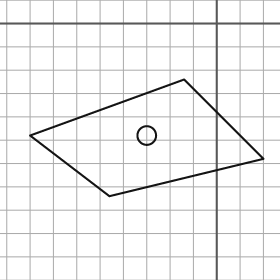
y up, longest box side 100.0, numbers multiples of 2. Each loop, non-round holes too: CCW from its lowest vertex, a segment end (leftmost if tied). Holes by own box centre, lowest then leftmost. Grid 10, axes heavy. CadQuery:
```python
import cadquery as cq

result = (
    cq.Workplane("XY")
    .moveTo(-46.0, -74.0)
    .lineTo(20.0, -58.0)
    .lineTo(-14.0, -24.0)
    .lineTo(-80.0, -48.0)
    .close()
    .moveTo(-30.0, -48.0)
    .circle(4.0)
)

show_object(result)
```